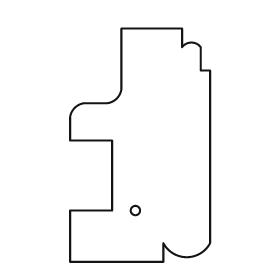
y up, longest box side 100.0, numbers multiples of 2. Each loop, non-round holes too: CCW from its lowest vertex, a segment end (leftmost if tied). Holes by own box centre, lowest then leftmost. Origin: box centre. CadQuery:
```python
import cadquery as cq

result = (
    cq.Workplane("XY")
    .moveTo(-30.0, -50.0)
    .lineTo(10.0, -50.0)
    .lineTo(10.0, -42.0)
    .threePointArc((20.0, -48.0), (30.0, -42.0))
    .lineTo(30.0, 32.0)
    .lineTo(26.0, 32.0)
    .lineTo(26.0, 42.0)
    .threePointArc((22.0, 44.0), (18.0, 42.0))
    .lineTo(18.0, 50.0)
    .lineTo(-8.0, 50.0)
    .lineTo(-8.0, 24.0)
    .threePointArc((-10.0, 20.0), (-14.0, 18.0))
    .lineTo(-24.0, 18.0)
    .threePointArc((-28.0, 16.0), (-30.0, 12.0))
    .lineTo(-30.0, 2.0)
    .lineTo(-12.0, 2.0)
    .lineTo(-12.0, -28.0)
    .lineTo(-30.0, -28.0)
    .close()
    .moveTo(-2.0, -28.0)
    .circle(2.0)
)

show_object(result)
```